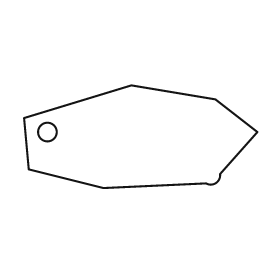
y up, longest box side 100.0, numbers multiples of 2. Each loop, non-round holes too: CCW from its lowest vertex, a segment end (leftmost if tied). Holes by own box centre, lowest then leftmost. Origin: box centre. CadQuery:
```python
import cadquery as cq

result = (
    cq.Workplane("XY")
    .moveTo(-16.0, -22.0)
    .lineTo(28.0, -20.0)
    .threePointArc((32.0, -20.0), (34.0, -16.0))
    .lineTo(50.0, 2.0)
    .lineTo(32.0, 16.0)
    .lineTo(-4.0, 22.0)
    .lineTo(-50.0, 8.0)
    .lineTo(-48.0, -14.0)
    .close()
    .moveTo(-40.0, 2.0)
    .circle(4.0)
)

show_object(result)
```